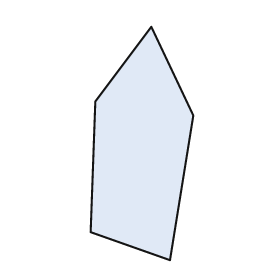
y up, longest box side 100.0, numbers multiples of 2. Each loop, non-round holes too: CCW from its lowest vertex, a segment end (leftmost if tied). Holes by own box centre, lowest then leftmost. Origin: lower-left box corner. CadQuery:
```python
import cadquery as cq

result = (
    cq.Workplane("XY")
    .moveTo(34.0, 0.0)
    .lineTo(44.0, 62.0)
    .lineTo(26.0, 100.0)
    .lineTo(2.0, 68.0)
    .lineTo(0.0, 12.0)
    .close()
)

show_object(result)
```